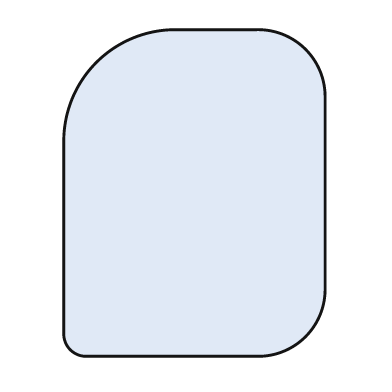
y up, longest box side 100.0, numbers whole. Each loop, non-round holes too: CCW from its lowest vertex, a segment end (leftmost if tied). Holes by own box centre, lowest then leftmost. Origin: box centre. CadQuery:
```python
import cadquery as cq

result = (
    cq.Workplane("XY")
    .moveTo(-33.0, -50.0)
    .lineTo(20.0, -50.0)
    .threePointArc((34.0, -44.0), (40.0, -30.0))
    .lineTo(40.0, 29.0)
    .threePointArc((34.0, 44.0), (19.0, 50.0))
    .lineTo(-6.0, 50.0)
    .threePointArc((-30.0, 40.0), (-40.0, 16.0))
    .lineTo(-40.0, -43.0)
    .threePointArc((-38.0, -48.0), (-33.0, -50.0))
    .close()
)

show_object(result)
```